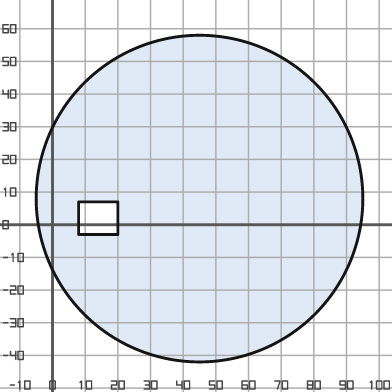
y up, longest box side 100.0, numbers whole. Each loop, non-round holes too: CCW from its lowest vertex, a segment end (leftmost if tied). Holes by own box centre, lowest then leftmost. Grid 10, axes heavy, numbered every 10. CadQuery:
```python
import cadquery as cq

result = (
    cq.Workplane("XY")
    .moveTo(45.0, 8.0)
    .circle(50.0)
    .moveTo(8.0, -3.0)
    .lineTo(20.0, -3.0)
    .lineTo(20.0, 7.0)
    .lineTo(8.0, 7.0)
    .close()
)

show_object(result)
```